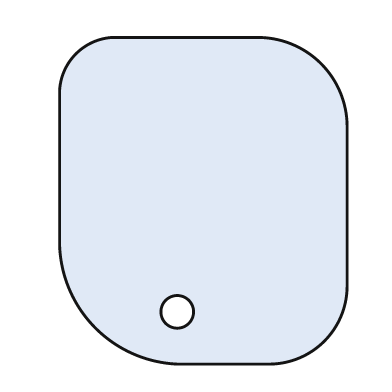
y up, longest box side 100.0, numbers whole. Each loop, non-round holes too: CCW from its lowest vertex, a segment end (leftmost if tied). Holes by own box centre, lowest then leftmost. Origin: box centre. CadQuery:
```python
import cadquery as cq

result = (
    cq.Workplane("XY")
    .moveTo(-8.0, -50.0)
    .lineTo(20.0, -50.0)
    .threePointArc((37.0, -43.0), (44.0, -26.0))
    .lineTo(44.0, 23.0)
    .threePointArc((36.0, 42.0), (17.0, 50.0))
    .lineTo(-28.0, 50.0)
    .threePointArc((-39.0, 45.0), (-44.0, 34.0))
    .lineTo(-44.0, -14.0)
    .threePointArc((-33.0, -39.0), (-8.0, -50.0))
    .close()
    .moveTo(-8.0, -34.0)
    .circle(5.0)
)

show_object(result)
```